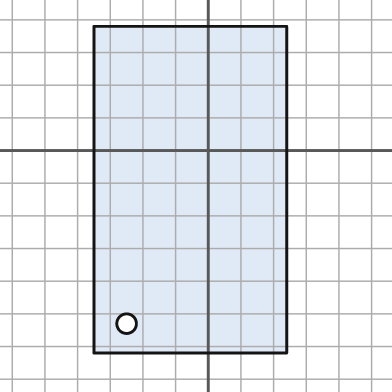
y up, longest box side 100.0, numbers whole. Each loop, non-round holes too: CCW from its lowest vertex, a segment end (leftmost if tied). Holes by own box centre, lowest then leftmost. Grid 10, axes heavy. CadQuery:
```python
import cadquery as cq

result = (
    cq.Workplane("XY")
    .moveTo(-35.0, -62.0)
    .lineTo(24.0, -62.0)
    .lineTo(24.0, 38.0)
    .lineTo(-35.0, 38.0)
    .close()
    .moveTo(-25.0, -53.0)
    .circle(3.0)
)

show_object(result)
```